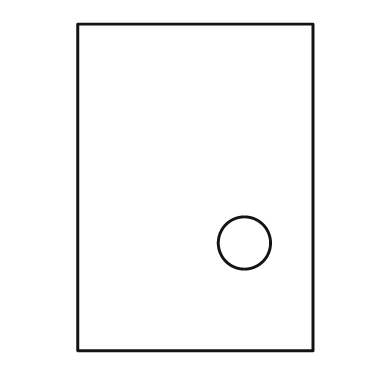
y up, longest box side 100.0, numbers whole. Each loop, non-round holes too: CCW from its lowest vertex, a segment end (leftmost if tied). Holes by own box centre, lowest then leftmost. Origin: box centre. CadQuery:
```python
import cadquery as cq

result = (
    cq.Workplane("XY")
    .moveTo(-36.0, -50.0)
    .lineTo(36.0, -50.0)
    .lineTo(36.0, 50.0)
    .lineTo(-36.0, 50.0)
    .close()
    .moveTo(15.0, -17.0)
    .circle(8.0)
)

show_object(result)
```